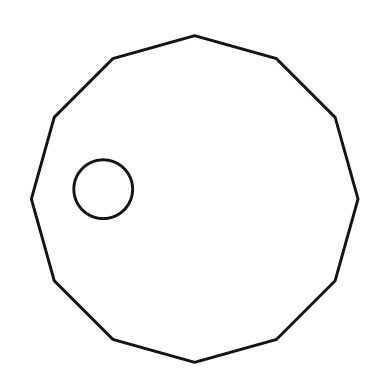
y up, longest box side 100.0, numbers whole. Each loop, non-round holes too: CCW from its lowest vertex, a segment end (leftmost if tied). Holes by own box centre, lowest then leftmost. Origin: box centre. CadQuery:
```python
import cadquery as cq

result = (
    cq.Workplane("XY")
    .moveTo(0.0, -50.0)
    .lineTo(25.0, -43.0)
    .lineTo(43.0, -25.0)
    .lineTo(50.0, 0.0)
    .lineTo(43.0, 25.0)
    .lineTo(25.0, 43.0)
    .lineTo(0.0, 50.0)
    .lineTo(-25.0, 43.0)
    .lineTo(-43.0, 25.0)
    .lineTo(-50.0, 0.0)
    .lineTo(-43.0, -25.0)
    .lineTo(-25.0, -43.0)
    .close()
    .moveTo(-28.0, 3.0)
    .circle(9.0)
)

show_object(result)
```